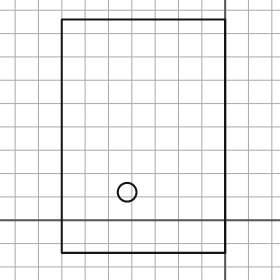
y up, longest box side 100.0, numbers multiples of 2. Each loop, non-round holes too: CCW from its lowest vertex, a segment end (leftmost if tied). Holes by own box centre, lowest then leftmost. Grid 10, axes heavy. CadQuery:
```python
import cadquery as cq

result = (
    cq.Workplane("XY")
    .moveTo(-70.0, -14.0)
    .lineTo(0.0, -14.0)
    .lineTo(0.0, 86.0)
    .lineTo(-70.0, 86.0)
    .close()
    .moveTo(-42.0, 12.0)
    .circle(4.0)
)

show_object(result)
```